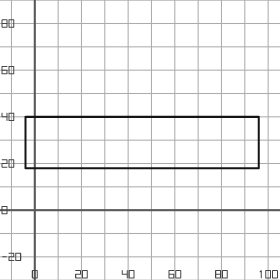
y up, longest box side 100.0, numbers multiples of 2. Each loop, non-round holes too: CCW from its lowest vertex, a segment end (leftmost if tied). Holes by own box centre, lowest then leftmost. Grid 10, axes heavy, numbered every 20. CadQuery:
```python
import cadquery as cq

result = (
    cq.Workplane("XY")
    .moveTo(-4.0, 18.0)
    .lineTo(96.0, 18.0)
    .lineTo(96.0, 40.0)
    .lineTo(-4.0, 40.0)
    .close()
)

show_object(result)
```